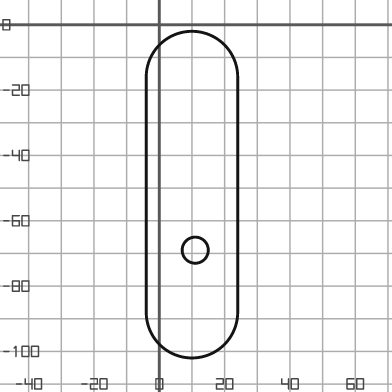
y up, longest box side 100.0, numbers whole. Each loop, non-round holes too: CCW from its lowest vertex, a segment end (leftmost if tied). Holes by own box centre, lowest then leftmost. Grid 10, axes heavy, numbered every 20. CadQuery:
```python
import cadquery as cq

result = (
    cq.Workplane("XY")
    .moveTo(-4.0, -88.0)
    .threePointArc((10.0, -102.0), (24.0, -88.0))
    .lineTo(24.0, -16.0)
    .threePointArc((10.0, -2.0), (-4.0, -16.0))
    .close()
    .moveTo(11.0, -69.0)
    .circle(4.0)
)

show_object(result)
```